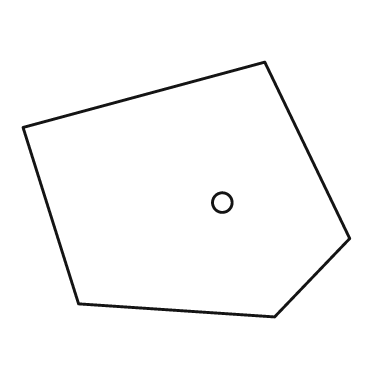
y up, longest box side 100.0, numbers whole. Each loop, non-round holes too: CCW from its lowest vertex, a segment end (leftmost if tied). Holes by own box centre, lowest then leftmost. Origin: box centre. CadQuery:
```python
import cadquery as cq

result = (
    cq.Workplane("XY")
    .moveTo(27.0, -39.0)
    .lineTo(50.0, -15.0)
    .lineTo(24.0, 39.0)
    .lineTo(-50.0, 19.0)
    .lineTo(-33.0, -35.0)
    .close()
    .moveTo(11.0, -4.0)
    .circle(3.0)
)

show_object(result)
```